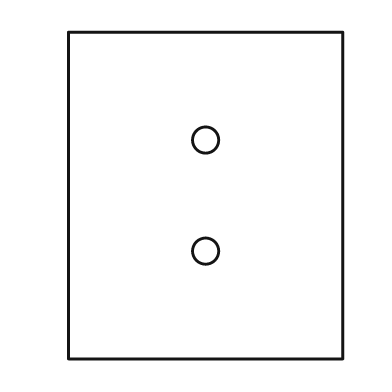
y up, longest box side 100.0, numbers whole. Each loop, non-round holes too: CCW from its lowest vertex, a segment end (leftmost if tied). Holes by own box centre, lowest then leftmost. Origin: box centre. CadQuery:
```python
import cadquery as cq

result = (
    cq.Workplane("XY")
    .moveTo(-42.0, -50.0)
    .lineTo(42.0, -50.0)
    .lineTo(42.0, 50.0)
    .lineTo(-42.0, 50.0)
    .close()
    .moveTo(0.0, -17.0)
    .circle(4.0)
    .moveTo(0.0, 17.0)
    .circle(4.0)
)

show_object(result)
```